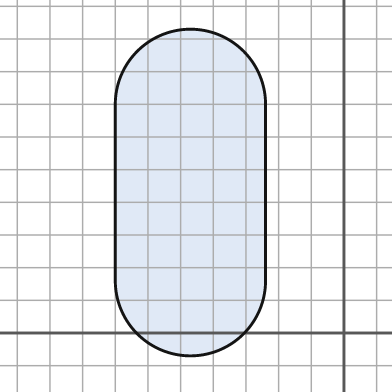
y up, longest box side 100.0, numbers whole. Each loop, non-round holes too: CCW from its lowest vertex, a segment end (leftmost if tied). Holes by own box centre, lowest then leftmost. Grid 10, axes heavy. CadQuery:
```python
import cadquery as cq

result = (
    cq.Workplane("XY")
    .moveTo(-70.0, 16.0)
    .threePointArc((-47.0, -7.0), (-24.0, 16.0))
    .lineTo(-24.0, 70.0)
    .threePointArc((-47.0, 93.0), (-70.0, 70.0))
    .close()
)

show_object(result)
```